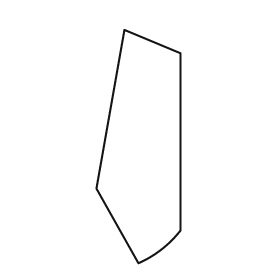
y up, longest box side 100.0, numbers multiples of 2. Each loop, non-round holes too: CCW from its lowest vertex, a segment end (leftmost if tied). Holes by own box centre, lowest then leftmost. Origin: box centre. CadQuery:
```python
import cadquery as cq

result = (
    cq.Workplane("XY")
    .moveTo(0.0, -50.0)
    .threePointArc((10.0, -44.0), (18.0, -36.0))
    .lineTo(18.0, 40.0)
    .lineTo(-6.0, 50.0)
    .lineTo(-18.0, -18.0)
    .close()
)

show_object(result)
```